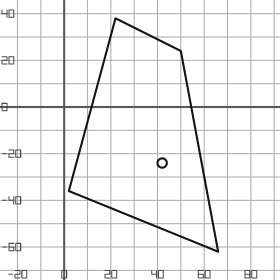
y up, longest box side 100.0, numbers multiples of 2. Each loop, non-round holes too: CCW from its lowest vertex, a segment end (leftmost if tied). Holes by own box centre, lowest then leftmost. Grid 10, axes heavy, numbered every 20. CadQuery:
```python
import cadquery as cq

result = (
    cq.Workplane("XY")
    .moveTo(66.0, -62.0)
    .lineTo(50.0, 24.0)
    .lineTo(22.0, 38.0)
    .lineTo(2.0, -36.0)
    .close()
    .moveTo(42.0, -24.0)
    .circle(2.0)
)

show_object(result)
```